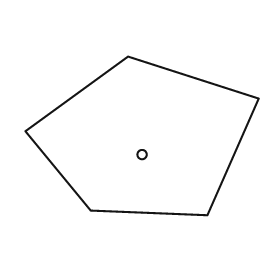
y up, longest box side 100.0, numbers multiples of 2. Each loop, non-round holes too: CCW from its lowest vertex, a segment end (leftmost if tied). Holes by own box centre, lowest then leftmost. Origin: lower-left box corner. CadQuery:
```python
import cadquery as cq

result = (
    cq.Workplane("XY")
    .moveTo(78.0, 0.0)
    .lineTo(100.0, 50.0)
    .lineTo(44.0, 68.0)
    .lineTo(0.0, 36.0)
    .lineTo(28.0, 2.0)
    .close()
    .moveTo(50.0, 26.0)
    .circle(2.0)
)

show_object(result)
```